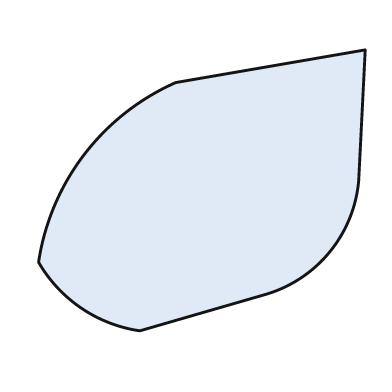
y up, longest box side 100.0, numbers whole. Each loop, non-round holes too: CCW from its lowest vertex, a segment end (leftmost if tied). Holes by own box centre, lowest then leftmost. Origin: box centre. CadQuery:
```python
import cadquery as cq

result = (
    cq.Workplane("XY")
    .moveTo(-19.0, -43.0)
    .lineTo(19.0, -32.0)
    .threePointArc((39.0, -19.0), (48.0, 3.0))
    .lineTo(50.0, 43.0)
    .lineTo(-8.0, 33.0)
    .threePointArc((-36.0, 11.0), (-50.0, -22.0))
    .threePointArc((-37.0, -36.0), (-19.0, -43.0))
    .close()
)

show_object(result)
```